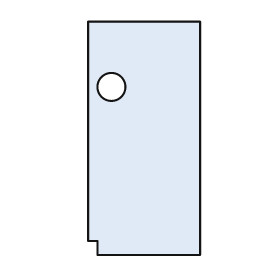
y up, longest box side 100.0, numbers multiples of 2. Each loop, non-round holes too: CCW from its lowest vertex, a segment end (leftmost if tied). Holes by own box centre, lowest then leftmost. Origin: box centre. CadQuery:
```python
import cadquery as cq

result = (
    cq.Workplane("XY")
    .moveTo(-20.0, -50.0)
    .lineTo(24.0, -50.0)
    .lineTo(24.0, 50.0)
    .lineTo(-24.0, 50.0)
    .lineTo(-24.0, -44.0)
    .lineTo(-20.0, -44.0)
    .close()
    .moveTo(-14.0, 22.0)
    .circle(6.0)
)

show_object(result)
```